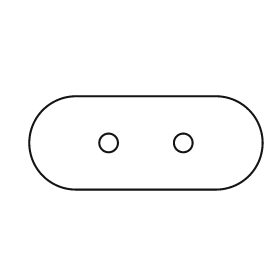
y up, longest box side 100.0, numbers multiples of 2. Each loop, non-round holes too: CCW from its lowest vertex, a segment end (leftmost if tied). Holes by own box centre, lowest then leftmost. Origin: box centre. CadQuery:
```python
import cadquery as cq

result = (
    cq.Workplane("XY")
    .moveTo(-30.0, -20.0)
    .lineTo(30.0, -20.0)
    .threePointArc((50.0, 0.0), (30.0, 20.0))
    .lineTo(-30.0, 20.0)
    .threePointArc((-50.0, 0.0), (-30.0, -20.0))
    .close()
    .moveTo(-16.0, 0.0)
    .circle(4.0)
    .moveTo(16.0, 0.0)
    .circle(4.0)
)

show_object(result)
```